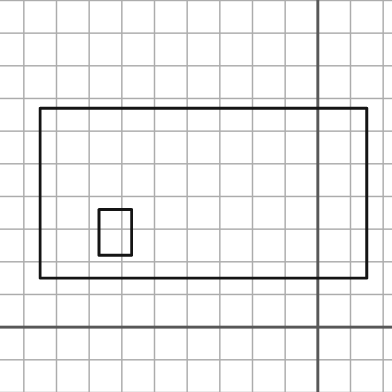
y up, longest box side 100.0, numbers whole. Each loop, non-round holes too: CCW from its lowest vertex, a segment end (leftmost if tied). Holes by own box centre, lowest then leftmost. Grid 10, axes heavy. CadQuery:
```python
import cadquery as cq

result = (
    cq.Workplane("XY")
    .moveTo(-85.0, 15.0)
    .lineTo(15.0, 15.0)
    .lineTo(15.0, 67.0)
    .lineTo(-85.0, 67.0)
    .close()
    .moveTo(-67.0, 22.0)
    .lineTo(-57.0, 22.0)
    .lineTo(-57.0, 36.0)
    .lineTo(-67.0, 36.0)
    .close()
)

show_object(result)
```